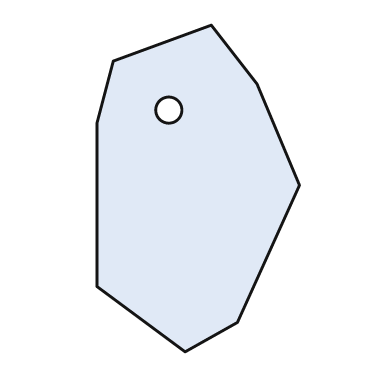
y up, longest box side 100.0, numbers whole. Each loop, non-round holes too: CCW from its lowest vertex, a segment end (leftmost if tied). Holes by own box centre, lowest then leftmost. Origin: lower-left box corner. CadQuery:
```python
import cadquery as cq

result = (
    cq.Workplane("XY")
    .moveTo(27.0, 0.0)
    .lineTo(43.0, 9.0)
    .lineTo(62.0, 51.0)
    .lineTo(49.0, 82.0)
    .lineTo(35.0, 100.0)
    .lineTo(5.0, 89.0)
    .lineTo(0.0, 70.0)
    .lineTo(0.0, 20.0)
    .close()
    .moveTo(22.0, 74.0)
    .circle(4.0)
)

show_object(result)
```